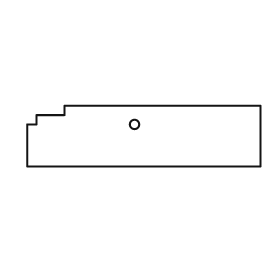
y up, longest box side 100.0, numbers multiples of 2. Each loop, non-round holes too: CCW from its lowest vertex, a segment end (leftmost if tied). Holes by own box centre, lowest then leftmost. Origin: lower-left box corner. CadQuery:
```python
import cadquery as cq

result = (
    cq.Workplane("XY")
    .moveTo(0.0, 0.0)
    .lineTo(100.0, 0.0)
    .lineTo(100.0, 26.0)
    .lineTo(16.0, 26.0)
    .lineTo(16.0, 22.0)
    .lineTo(4.0, 22.0)
    .lineTo(4.0, 18.0)
    .lineTo(0.0, 18.0)
    .close()
    .moveTo(46.0, 18.0)
    .circle(2.0)
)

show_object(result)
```